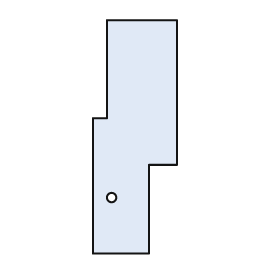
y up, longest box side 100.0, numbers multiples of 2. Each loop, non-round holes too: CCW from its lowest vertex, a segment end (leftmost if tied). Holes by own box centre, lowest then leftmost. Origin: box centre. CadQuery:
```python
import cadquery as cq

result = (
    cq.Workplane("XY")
    .moveTo(-18.0, -50.0)
    .lineTo(6.0, -50.0)
    .lineTo(6.0, -12.0)
    .lineTo(18.0, -12.0)
    .lineTo(18.0, 50.0)
    .lineTo(-12.0, 50.0)
    .lineTo(-12.0, 8.0)
    .lineTo(-18.0, 8.0)
    .close()
    .moveTo(-10.0, -26.0)
    .circle(2.0)
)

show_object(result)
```